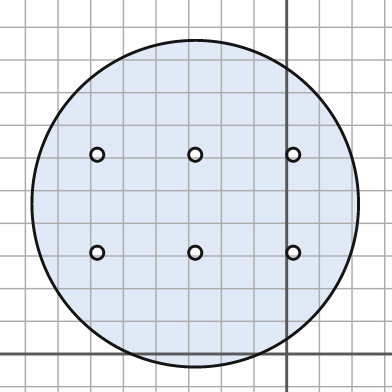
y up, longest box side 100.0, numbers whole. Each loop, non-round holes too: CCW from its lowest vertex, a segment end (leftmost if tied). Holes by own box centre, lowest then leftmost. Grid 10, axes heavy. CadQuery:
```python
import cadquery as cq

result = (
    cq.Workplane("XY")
    .moveTo(-28.0, 46.0)
    .circle(50.0)
    .moveTo(-58.0, 31.0)
    .circle(2.0)
    .moveTo(-28.0, 31.0)
    .circle(2.0)
    .moveTo(2.0, 31.0)
    .circle(2.0)
    .moveTo(-58.0, 61.0)
    .circle(2.0)
    .moveTo(-28.0, 61.0)
    .circle(2.0)
    .moveTo(2.0, 61.0)
    .circle(2.0)
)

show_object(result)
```